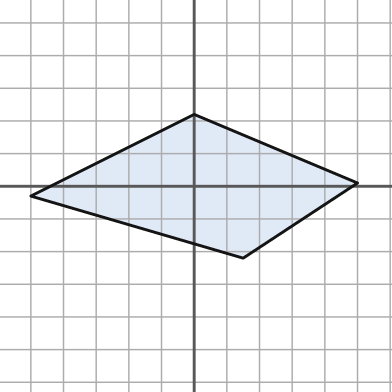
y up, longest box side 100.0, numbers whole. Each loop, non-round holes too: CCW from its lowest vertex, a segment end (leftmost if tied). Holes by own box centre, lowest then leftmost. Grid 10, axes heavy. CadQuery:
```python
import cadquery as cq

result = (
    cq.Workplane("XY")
    .moveTo(15.0, -22.0)
    .lineTo(50.0, 1.0)
    .lineTo(0.0, 22.0)
    .lineTo(-50.0, -3.0)
    .close()
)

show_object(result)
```